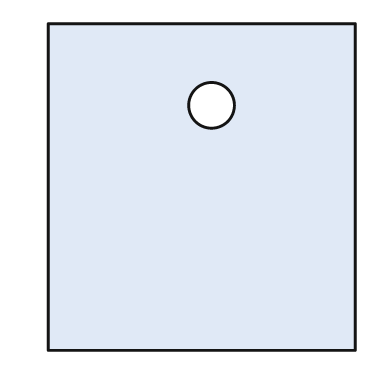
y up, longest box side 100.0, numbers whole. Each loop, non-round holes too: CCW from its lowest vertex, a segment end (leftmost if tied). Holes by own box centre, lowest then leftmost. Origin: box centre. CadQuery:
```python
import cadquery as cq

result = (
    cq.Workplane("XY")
    .moveTo(-47.0, -50.0)
    .lineTo(47.0, -50.0)
    .lineTo(47.0, 50.0)
    .lineTo(-47.0, 50.0)
    .close()
    .moveTo(3.0, 25.0)
    .circle(7.0)
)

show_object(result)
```